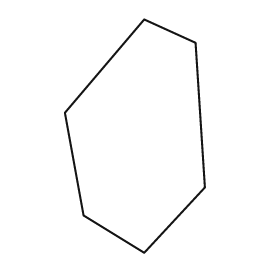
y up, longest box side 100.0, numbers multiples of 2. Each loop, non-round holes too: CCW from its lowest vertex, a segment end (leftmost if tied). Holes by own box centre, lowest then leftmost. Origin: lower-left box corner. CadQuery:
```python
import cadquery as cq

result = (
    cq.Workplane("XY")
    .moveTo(34.0, 0.0)
    .lineTo(60.0, 28.0)
    .lineTo(56.0, 90.0)
    .lineTo(34.0, 100.0)
    .lineTo(0.0, 60.0)
    .lineTo(8.0, 16.0)
    .close()
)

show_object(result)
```